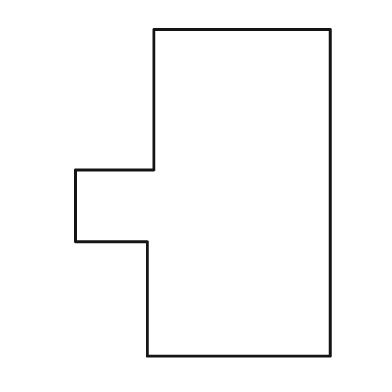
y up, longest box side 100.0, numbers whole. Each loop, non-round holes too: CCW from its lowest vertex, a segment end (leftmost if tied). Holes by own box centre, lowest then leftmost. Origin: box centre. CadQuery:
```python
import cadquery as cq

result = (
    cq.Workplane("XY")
    .moveTo(-17.0, -50.0)
    .lineTo(39.0, -50.0)
    .lineTo(39.0, 50.0)
    .lineTo(-15.0, 50.0)
    .lineTo(-15.0, 7.0)
    .lineTo(-39.0, 7.0)
    .lineTo(-39.0, -15.0)
    .lineTo(-17.0, -15.0)
    .close()
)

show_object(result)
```